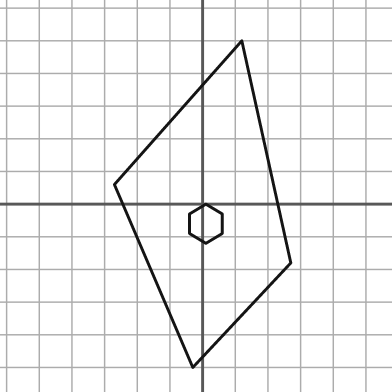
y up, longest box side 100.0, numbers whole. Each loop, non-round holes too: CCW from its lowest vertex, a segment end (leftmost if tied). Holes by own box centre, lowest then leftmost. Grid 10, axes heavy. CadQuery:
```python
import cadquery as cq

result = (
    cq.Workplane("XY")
    .moveTo(-3.0, -50.0)
    .lineTo(27.0, -18.0)
    .lineTo(12.0, 50.0)
    .lineTo(-27.0, 6.0)
    .close()
    .moveTo(1.0, -12.0)
    .lineTo(6.0, -9.0)
    .lineTo(6.0, -3.0)
    .lineTo(1.0, 0.0)
    .lineTo(-4.0, -3.0)
    .lineTo(-4.0, -9.0)
    .close()
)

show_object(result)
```